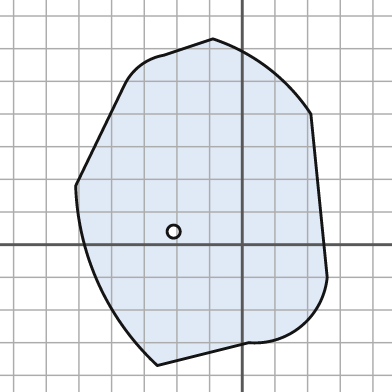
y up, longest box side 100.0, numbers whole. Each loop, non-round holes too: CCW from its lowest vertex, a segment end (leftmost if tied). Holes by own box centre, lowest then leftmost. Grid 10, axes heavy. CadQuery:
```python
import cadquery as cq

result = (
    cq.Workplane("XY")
    .moveTo(-26.0, -37.0)
    .lineTo(2.0, -30.0)
    .threePointArc((18.0, -25.0), (26.0, -10.0))
    .lineTo(21.0, 40.0)
    .threePointArc((8.0, 54.0), (-9.0, 63.0))
    .lineTo(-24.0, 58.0)
    .threePointArc((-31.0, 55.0), (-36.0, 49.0))
    .lineTo(-51.0, 18.0)
    .threePointArc((-44.0, -12.0), (-26.0, -37.0))
    .close()
    .moveTo(-21.0, 4.0)
    .circle(2.0)
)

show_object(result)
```